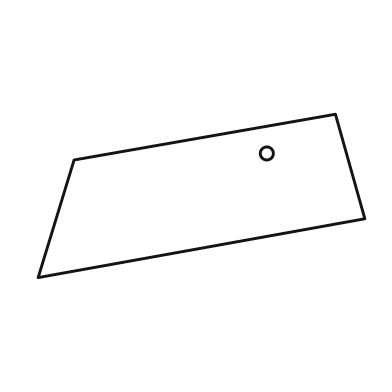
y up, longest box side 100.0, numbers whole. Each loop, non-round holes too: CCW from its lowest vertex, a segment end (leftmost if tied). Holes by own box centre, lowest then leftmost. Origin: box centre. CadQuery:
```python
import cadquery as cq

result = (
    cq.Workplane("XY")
    .moveTo(-50.0, -25.0)
    .lineTo(50.0, -7.0)
    .lineTo(41.0, 25.0)
    .lineTo(-39.0, 11.0)
    .close()
    .moveTo(20.0, 13.0)
    .circle(2.0)
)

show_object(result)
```